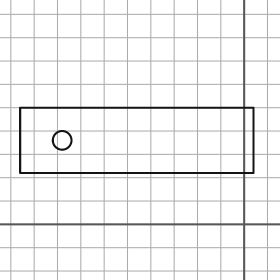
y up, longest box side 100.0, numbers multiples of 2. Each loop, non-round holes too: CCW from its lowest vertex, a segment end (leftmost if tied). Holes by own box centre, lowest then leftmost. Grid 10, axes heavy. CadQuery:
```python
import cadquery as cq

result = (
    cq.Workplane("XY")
    .moveTo(-96.0, 22.0)
    .lineTo(4.0, 22.0)
    .lineTo(4.0, 50.0)
    .lineTo(-96.0, 50.0)
    .close()
    .moveTo(-78.0, 36.0)
    .circle(4.0)
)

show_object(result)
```